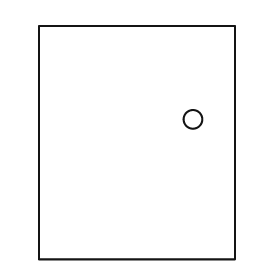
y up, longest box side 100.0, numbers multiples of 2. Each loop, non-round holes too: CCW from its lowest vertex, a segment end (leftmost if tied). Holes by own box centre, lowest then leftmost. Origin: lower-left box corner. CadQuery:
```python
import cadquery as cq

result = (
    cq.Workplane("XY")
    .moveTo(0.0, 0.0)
    .lineTo(84.0, 0.0)
    .lineTo(84.0, 100.0)
    .lineTo(0.0, 100.0)
    .close()
    .moveTo(66.0, 60.0)
    .circle(4.0)
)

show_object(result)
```